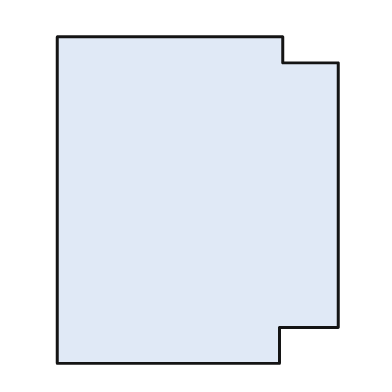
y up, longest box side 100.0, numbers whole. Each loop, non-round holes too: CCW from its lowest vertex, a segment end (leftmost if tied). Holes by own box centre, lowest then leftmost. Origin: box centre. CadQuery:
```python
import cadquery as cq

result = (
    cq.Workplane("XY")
    .moveTo(-43.0, -50.0)
    .lineTo(25.0, -50.0)
    .lineTo(25.0, -39.0)
    .lineTo(43.0, -39.0)
    .lineTo(43.0, 42.0)
    .lineTo(26.0, 42.0)
    .lineTo(26.0, 50.0)
    .lineTo(-43.0, 50.0)
    .close()
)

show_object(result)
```